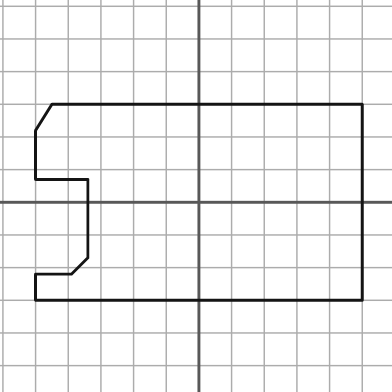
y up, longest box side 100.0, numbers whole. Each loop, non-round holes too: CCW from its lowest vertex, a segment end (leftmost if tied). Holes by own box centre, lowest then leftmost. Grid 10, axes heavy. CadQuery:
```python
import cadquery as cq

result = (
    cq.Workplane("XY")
    .moveTo(-50.0, -30.0)
    .lineTo(50.0, -30.0)
    .lineTo(50.0, 30.0)
    .lineTo(-45.0, 30.0)
    .lineTo(-50.0, 22.0)
    .lineTo(-50.0, 7.0)
    .lineTo(-34.0, 7.0)
    .lineTo(-34.0, -17.0)
    .lineTo(-39.0, -22.0)
    .lineTo(-50.0, -22.0)
    .close()
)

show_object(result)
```